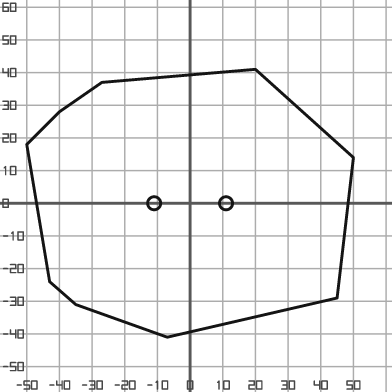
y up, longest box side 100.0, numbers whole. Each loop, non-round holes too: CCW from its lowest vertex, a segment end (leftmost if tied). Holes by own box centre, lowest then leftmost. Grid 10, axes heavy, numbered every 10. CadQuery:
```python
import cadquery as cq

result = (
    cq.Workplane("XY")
    .moveTo(-7.0, -41.0)
    .lineTo(45.0, -29.0)
    .lineTo(50.0, 14.0)
    .lineTo(20.0, 41.0)
    .lineTo(-27.0, 37.0)
    .lineTo(-40.0, 28.0)
    .lineTo(-50.0, 18.0)
    .lineTo(-43.0, -24.0)
    .lineTo(-35.0, -31.0)
    .close()
    .moveTo(-11.0, 0.0)
    .circle(2.0)
    .moveTo(11.0, 0.0)
    .circle(2.0)
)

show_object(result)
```